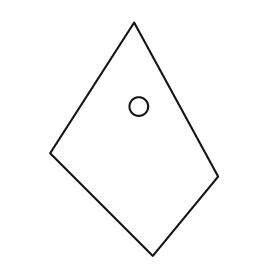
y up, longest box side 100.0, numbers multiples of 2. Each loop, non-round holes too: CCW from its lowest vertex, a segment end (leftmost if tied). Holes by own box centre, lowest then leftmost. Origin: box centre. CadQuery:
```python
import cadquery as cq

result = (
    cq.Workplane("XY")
    .moveTo(8.0, -50.0)
    .lineTo(36.0, -16.0)
    .lineTo(0.0, 50.0)
    .lineTo(-36.0, -6.0)
    .close()
    .moveTo(2.0, 14.0)
    .circle(4.0)
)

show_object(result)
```